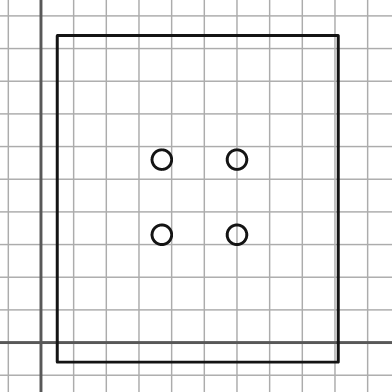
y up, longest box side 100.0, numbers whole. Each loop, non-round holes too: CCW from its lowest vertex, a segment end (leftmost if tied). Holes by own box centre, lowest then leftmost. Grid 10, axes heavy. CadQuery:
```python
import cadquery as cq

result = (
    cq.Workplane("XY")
    .moveTo(5.0, -6.0)
    .lineTo(91.0, -6.0)
    .lineTo(91.0, 94.0)
    .lineTo(5.0, 94.0)
    .close()
    .moveTo(37.0, 33.0)
    .circle(3.0)
    .moveTo(60.0, 33.0)
    .circle(3.0)
    .moveTo(37.0, 56.0)
    .circle(3.0)
    .moveTo(60.0, 56.0)
    .circle(3.0)
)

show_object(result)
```